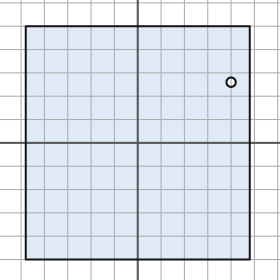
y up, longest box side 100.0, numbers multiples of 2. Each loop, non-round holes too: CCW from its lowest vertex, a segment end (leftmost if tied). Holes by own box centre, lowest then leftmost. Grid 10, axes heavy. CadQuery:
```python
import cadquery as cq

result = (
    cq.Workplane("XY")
    .moveTo(-48.0, -50.0)
    .lineTo(48.0, -50.0)
    .lineTo(48.0, 50.0)
    .lineTo(-48.0, 50.0)
    .close()
    .moveTo(40.0, 26.0)
    .circle(2.0)
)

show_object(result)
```